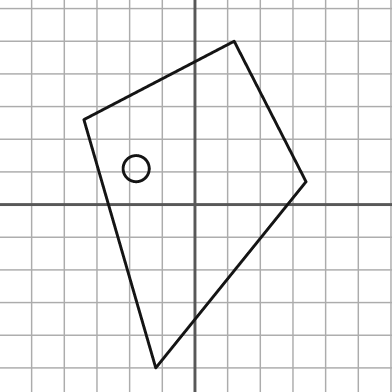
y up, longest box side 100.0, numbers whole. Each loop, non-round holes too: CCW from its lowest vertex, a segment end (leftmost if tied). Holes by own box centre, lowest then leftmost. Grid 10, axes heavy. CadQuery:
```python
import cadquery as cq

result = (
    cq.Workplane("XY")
    .moveTo(-12.0, -50.0)
    .lineTo(34.0, 7.0)
    .lineTo(12.0, 50.0)
    .lineTo(-34.0, 26.0)
    .close()
    .moveTo(-18.0, 11.0)
    .circle(4.0)
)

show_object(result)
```